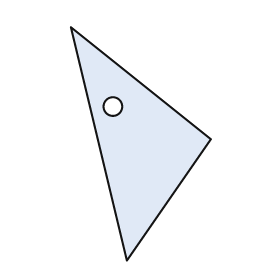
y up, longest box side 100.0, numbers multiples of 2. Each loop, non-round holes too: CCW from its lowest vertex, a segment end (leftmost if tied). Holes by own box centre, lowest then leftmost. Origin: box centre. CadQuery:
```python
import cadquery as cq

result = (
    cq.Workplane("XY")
    .moveTo(-6.0, -50.0)
    .lineTo(30.0, 2.0)
    .lineTo(-30.0, 50.0)
    .close()
    .moveTo(-12.0, 16.0)
    .circle(4.0)
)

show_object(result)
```